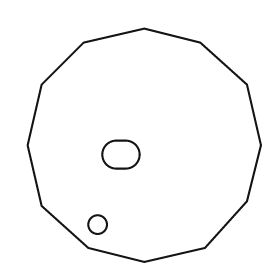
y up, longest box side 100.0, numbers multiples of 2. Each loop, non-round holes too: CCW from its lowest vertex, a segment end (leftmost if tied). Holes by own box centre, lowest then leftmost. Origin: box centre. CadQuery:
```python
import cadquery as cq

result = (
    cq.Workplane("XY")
    .moveTo(0.0, -50.0)
    .lineTo(26.0, -44.0)
    .lineTo(44.0, -24.0)
    .lineTo(50.0, 0.0)
    .lineTo(44.0, 26.0)
    .lineTo(24.0, 44.0)
    .lineTo(0.0, 50.0)
    .lineTo(-26.0, 44.0)
    .lineTo(-44.0, 26.0)
    .lineTo(-50.0, 0.0)
    .lineTo(-44.0, -26.0)
    .lineTo(-24.0, -44.0)
    .close()
    .moveTo(-20.0, -34.0)
    .circle(4.0)
    .moveTo(-12.0, -10.0)
    .lineTo(-8.0, -10.0)
    .threePointArc((-2.0, -4.0), (-8.0, 2.0))
    .lineTo(-12.0, 2.0)
    .threePointArc((-18.0, -4.0), (-12.0, -10.0))
    .close()
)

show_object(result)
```